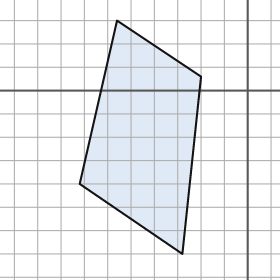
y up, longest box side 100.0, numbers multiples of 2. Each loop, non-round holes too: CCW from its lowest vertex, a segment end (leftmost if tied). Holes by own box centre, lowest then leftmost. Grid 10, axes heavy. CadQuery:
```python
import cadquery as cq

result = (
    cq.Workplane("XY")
    .moveTo(-28.0, -70.0)
    .lineTo(-20.0, 6.0)
    .lineTo(-56.0, 30.0)
    .lineTo(-72.0, -40.0)
    .close()
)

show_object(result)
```